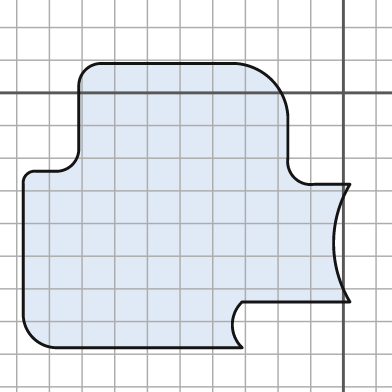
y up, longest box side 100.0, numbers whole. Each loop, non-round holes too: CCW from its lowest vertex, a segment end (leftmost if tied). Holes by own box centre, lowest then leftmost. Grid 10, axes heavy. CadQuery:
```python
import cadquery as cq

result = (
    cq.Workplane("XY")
    .moveTo(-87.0, -78.0)
    .lineTo(-31.0, -78.0)
    .threePointArc((-34.0, -71.0), (-31.0, -64.0))
    .lineTo(2.0, -64.0)
    .threePointArc((-3.0, -46.0), (2.0, -28.0))
    .lineTo(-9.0, -28.0)
    .threePointArc((-15.0, -26.0), (-17.0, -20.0))
    .lineTo(-17.0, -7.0)
    .threePointArc((-22.0, 4.0), (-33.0, 9.0))
    .lineTo(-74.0, 9.0)
    .threePointArc((-79.0, 7.0), (-81.0, 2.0))
    .lineTo(-81.0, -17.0)
    .threePointArc((-83.0, -22.0), (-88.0, -24.0))
    .lineTo(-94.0, -24.0)
    .threePointArc((-97.0, -25.0), (-98.0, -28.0))
    .lineTo(-98.0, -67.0)
    .threePointArc((-95.0, -75.0), (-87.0, -78.0))
    .close()
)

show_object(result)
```